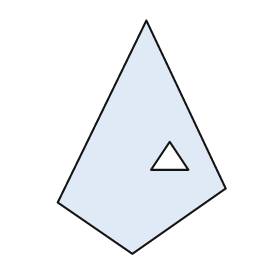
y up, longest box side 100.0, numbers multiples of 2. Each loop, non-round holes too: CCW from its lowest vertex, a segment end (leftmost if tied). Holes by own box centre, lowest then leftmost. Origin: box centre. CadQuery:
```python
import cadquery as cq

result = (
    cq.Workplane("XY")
    .moveTo(-4.0, -50.0)
    .lineTo(36.0, -22.0)
    .lineTo(2.0, 50.0)
    .lineTo(-36.0, -28.0)
    .close()
    .moveTo(4.0, -14.0)
    .lineTo(20.0, -14.0)
    .lineTo(12.0, -2.0)
    .close()
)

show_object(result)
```